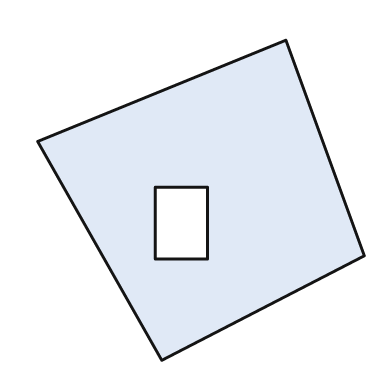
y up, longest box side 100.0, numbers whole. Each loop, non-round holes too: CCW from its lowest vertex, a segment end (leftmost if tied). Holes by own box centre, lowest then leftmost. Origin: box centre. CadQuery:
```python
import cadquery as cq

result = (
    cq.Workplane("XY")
    .moveTo(-12.0, -49.0)
    .lineTo(50.0, -17.0)
    .lineTo(26.0, 49.0)
    .lineTo(-50.0, 18.0)
    .close()
    .moveTo(-14.0, -18.0)
    .lineTo(2.0, -18.0)
    .lineTo(2.0, 4.0)
    .lineTo(-14.0, 4.0)
    .close()
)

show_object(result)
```